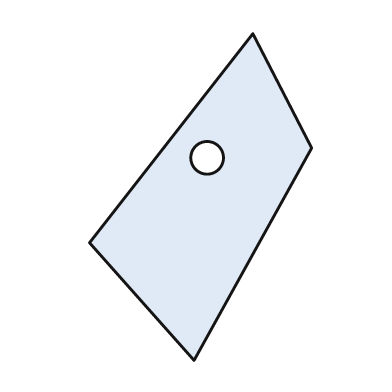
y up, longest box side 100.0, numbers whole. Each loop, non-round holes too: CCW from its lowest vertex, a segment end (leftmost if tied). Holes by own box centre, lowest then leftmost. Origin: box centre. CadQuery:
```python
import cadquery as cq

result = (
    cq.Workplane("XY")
    .moveTo(-2.0, -50.0)
    .lineTo(34.0, 15.0)
    .lineTo(16.0, 50.0)
    .lineTo(-34.0, -14.0)
    .close()
    .moveTo(2.0, 12.0)
    .circle(5.0)
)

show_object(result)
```